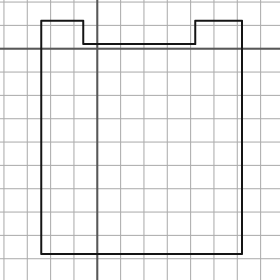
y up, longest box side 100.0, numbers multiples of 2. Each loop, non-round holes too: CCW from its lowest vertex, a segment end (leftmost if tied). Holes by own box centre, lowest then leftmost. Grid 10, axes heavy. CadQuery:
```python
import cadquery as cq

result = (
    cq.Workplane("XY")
    .moveTo(-24.0, -88.0)
    .lineTo(62.0, -88.0)
    .lineTo(62.0, 12.0)
    .lineTo(42.0, 12.0)
    .lineTo(42.0, 2.0)
    .lineTo(-6.0, 2.0)
    .lineTo(-6.0, 12.0)
    .lineTo(-24.0, 12.0)
    .close()
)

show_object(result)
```